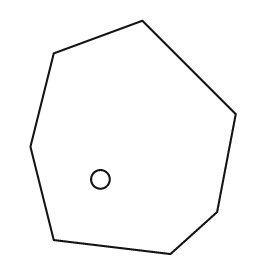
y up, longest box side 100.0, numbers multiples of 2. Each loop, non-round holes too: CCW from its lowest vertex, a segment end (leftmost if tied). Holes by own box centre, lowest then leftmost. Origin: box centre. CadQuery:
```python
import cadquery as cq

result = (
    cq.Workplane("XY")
    .moveTo(16.0, -50.0)
    .lineTo(36.0, -32.0)
    .lineTo(44.0, 10.0)
    .lineTo(4.0, 50.0)
    .lineTo(-34.0, 36.0)
    .lineTo(-44.0, -4.0)
    .lineTo(-34.0, -44.0)
    .close()
    .moveTo(-14.0, -18.0)
    .circle(4.0)
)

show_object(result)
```